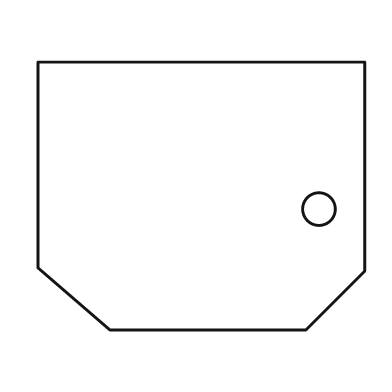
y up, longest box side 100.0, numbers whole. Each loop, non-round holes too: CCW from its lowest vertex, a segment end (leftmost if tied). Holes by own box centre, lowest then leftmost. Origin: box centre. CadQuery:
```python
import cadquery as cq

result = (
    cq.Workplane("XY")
    .moveTo(-28.0, -41.0)
    .lineTo(32.0, -41.0)
    .lineTo(50.0, -23.0)
    .lineTo(50.0, 41.0)
    .lineTo(-50.0, 41.0)
    .lineTo(-50.0, -22.0)
    .close()
    .moveTo(36.0, -4.0)
    .circle(5.0)
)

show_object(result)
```